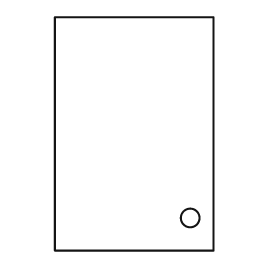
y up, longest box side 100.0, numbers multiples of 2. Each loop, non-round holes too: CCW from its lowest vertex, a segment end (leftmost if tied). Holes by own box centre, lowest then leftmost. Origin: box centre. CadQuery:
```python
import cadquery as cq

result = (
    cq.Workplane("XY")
    .moveTo(-34.0, -50.0)
    .lineTo(34.0, -50.0)
    .lineTo(34.0, 50.0)
    .lineTo(-34.0, 50.0)
    .close()
    .moveTo(24.0, -36.0)
    .circle(4.0)
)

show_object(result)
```